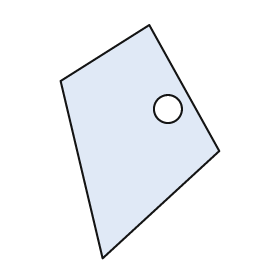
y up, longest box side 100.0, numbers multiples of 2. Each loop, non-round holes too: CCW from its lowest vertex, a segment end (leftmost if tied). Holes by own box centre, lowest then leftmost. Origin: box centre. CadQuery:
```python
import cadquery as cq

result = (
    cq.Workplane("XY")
    .moveTo(-16.0, -50.0)
    .lineTo(34.0, -4.0)
    .lineTo(4.0, 50.0)
    .lineTo(-34.0, 26.0)
    .close()
    .moveTo(12.0, 14.0)
    .circle(6.0)
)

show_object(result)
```